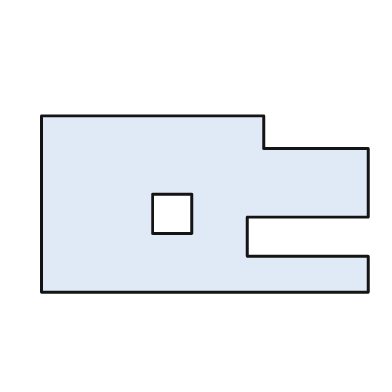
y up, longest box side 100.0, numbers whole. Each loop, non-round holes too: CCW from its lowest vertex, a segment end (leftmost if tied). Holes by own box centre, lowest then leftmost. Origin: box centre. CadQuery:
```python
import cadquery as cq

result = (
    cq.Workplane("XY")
    .moveTo(-50.0, -27.0)
    .lineTo(50.0, -27.0)
    .lineTo(50.0, -16.0)
    .lineTo(13.0, -16.0)
    .lineTo(13.0, -4.0)
    .lineTo(50.0, -4.0)
    .lineTo(50.0, 17.0)
    .lineTo(18.0, 17.0)
    .lineTo(18.0, 27.0)
    .lineTo(-50.0, 27.0)
    .close()
    .moveTo(-16.0, -9.0)
    .lineTo(-4.0, -9.0)
    .lineTo(-4.0, 3.0)
    .lineTo(-16.0, 3.0)
    .close()
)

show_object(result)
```